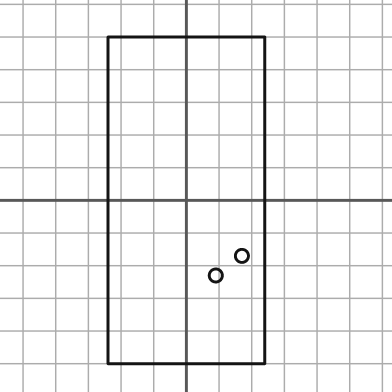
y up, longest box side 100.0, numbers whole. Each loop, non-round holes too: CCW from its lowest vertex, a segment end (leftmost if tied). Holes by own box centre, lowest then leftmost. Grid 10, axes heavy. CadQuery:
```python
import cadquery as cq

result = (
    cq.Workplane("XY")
    .moveTo(-24.0, -50.0)
    .lineTo(24.0, -50.0)
    .lineTo(24.0, 50.0)
    .lineTo(-24.0, 50.0)
    .close()
    .moveTo(9.0, -23.0)
    .circle(2.0)
    .moveTo(17.0, -17.0)
    .circle(2.0)
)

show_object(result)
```